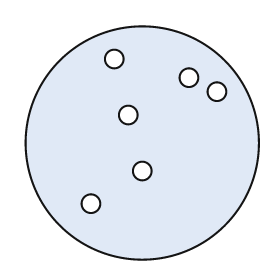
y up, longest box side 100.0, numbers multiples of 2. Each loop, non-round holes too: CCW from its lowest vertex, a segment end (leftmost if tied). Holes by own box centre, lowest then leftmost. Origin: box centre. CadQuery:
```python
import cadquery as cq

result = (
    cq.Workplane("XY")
    .moveTo(0.0, 0.0)
    .circle(50.0)
    .moveTo(-22.0, -26.0)
    .circle(4.0)
    .moveTo(0.0, -12.0)
    .circle(4.0)
    .moveTo(-6.0, 12.0)
    .circle(4.0)
    .moveTo(32.0, 22.0)
    .circle(4.0)
    .moveTo(20.0, 28.0)
    .circle(4.0)
    .moveTo(-12.0, 36.0)
    .circle(4.0)
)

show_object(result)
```